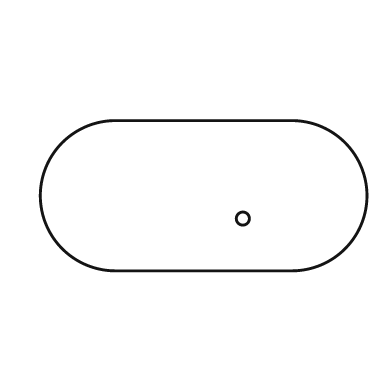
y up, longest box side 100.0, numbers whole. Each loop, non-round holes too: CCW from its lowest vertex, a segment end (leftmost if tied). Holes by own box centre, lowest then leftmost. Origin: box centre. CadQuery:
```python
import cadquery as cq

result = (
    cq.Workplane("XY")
    .moveTo(-27.0, -23.0)
    .lineTo(27.0, -23.0)
    .threePointArc((50.0, 0.0), (27.0, 23.0))
    .lineTo(-27.0, 23.0)
    .threePointArc((-50.0, 0.0), (-27.0, -23.0))
    .close()
    .moveTo(12.0, -7.0)
    .circle(2.0)
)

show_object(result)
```